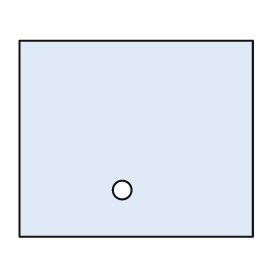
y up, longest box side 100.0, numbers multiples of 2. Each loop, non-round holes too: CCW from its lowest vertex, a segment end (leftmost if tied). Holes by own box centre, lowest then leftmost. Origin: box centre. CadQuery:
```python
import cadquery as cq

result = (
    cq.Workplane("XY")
    .moveTo(-50.0, -42.0)
    .lineTo(50.0, -42.0)
    .lineTo(50.0, 42.0)
    .lineTo(-50.0, 42.0)
    .close()
    .moveTo(-6.0, -22.0)
    .circle(4.0)
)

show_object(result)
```